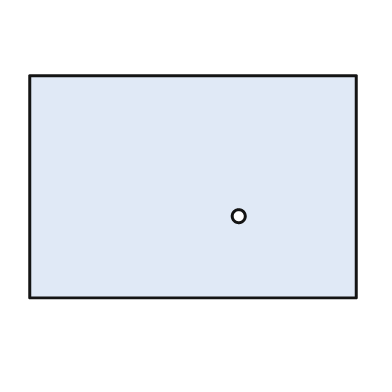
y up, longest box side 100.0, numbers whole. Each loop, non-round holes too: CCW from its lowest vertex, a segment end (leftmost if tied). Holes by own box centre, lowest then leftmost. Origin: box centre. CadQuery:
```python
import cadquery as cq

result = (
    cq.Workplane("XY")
    .moveTo(-50.0, -34.0)
    .lineTo(50.0, -34.0)
    .lineTo(50.0, 34.0)
    .lineTo(-50.0, 34.0)
    .close()
    .moveTo(14.0, -9.0)
    .circle(2.0)
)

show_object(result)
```